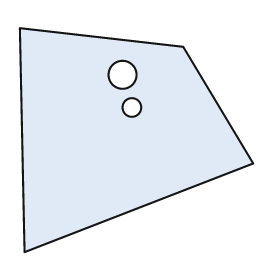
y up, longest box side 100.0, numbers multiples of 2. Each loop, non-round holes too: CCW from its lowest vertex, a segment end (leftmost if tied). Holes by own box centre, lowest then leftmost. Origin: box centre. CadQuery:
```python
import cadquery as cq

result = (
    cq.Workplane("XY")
    .moveTo(-48.0, -48.0)
    .lineTo(50.0, -10.0)
    .lineTo(20.0, 40.0)
    .lineTo(-50.0, 48.0)
    .close()
    .moveTo(-2.0, 14.0)
    .circle(4.0)
    .moveTo(-6.0, 28.0)
    .circle(6.0)
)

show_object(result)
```